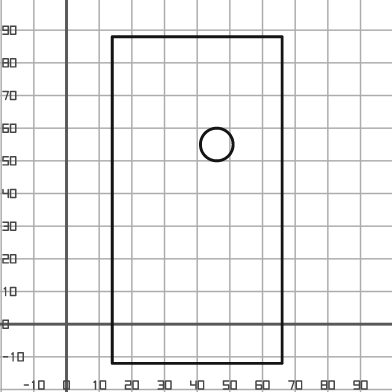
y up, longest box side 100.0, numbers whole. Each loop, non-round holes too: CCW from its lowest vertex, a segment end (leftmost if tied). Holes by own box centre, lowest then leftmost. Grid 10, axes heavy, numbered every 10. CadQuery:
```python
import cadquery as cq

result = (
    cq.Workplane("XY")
    .moveTo(14.0, -12.0)
    .lineTo(66.0, -12.0)
    .lineTo(66.0, 88.0)
    .lineTo(14.0, 88.0)
    .close()
    .moveTo(46.0, 55.0)
    .circle(5.0)
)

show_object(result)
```